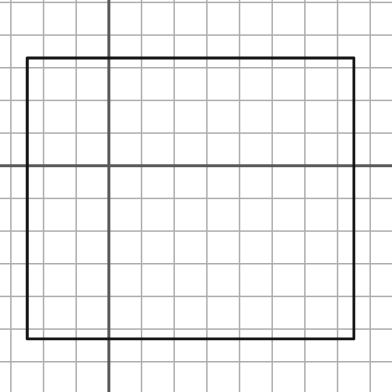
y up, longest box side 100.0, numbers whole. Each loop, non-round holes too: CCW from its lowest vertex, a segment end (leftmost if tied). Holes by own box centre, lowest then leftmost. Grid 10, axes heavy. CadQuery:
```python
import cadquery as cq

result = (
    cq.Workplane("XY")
    .moveTo(-25.0, -53.0)
    .lineTo(75.0, -53.0)
    .lineTo(75.0, 33.0)
    .lineTo(-25.0, 33.0)
    .close()
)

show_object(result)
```